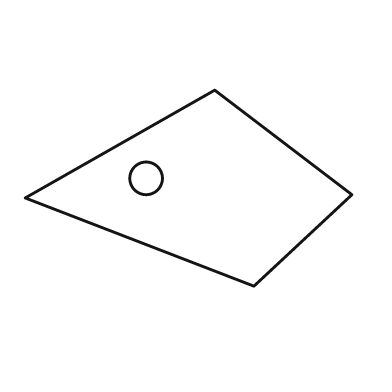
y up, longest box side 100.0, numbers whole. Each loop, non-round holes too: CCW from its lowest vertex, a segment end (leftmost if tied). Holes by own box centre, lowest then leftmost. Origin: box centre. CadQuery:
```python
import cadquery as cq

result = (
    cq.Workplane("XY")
    .moveTo(20.0, -30.0)
    .lineTo(50.0, -2.0)
    .lineTo(8.0, 30.0)
    .lineTo(-50.0, -3.0)
    .close()
    .moveTo(-13.0, 3.0)
    .circle(5.0)
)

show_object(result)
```